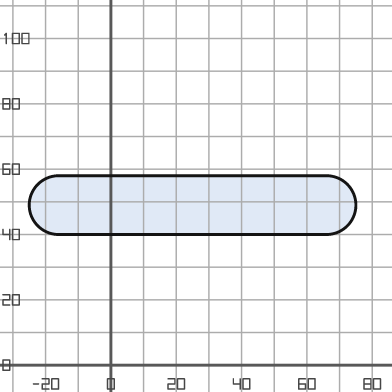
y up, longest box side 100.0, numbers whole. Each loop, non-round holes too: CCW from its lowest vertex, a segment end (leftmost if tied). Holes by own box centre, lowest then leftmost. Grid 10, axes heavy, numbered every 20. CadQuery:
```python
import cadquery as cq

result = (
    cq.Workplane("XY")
    .moveTo(-16.0, 40.0)
    .lineTo(66.0, 40.0)
    .threePointArc((75.0, 49.0), (66.0, 58.0))
    .lineTo(-16.0, 58.0)
    .threePointArc((-25.0, 49.0), (-16.0, 40.0))
    .close()
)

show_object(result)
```